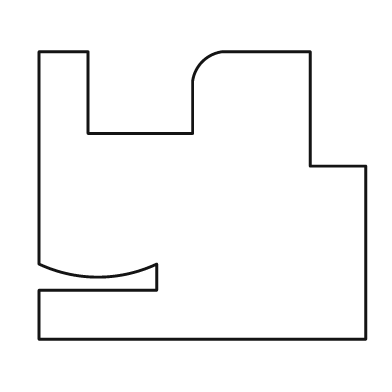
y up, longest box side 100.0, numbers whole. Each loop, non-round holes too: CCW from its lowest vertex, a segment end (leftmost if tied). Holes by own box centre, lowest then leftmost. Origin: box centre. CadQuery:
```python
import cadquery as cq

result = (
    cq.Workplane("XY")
    .moveTo(-50.0, -44.0)
    .lineTo(50.0, -44.0)
    .lineTo(50.0, 9.0)
    .lineTo(33.0, 9.0)
    .lineTo(33.0, 44.0)
    .lineTo(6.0, 44.0)
    .threePointArc((0.0, 41.0), (-3.0, 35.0))
    .lineTo(-3.0, 19.0)
    .lineTo(-35.0, 19.0)
    .lineTo(-35.0, 44.0)
    .lineTo(-50.0, 44.0)
    .lineTo(-50.0, -21.0)
    .threePointArc((-32.0, -25.0), (-14.0, -21.0))
    .lineTo(-14.0, -29.0)
    .lineTo(-50.0, -29.0)
    .close()
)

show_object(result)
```